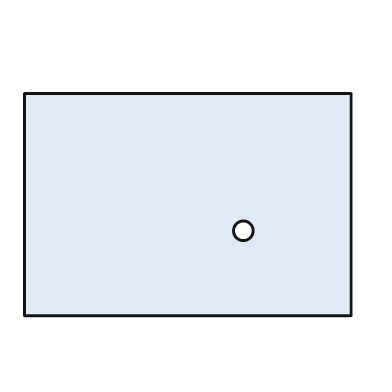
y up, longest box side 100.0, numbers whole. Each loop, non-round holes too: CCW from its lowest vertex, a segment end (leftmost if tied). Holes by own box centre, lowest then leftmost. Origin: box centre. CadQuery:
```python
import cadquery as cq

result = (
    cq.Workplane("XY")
    .moveTo(-50.0, -34.0)
    .lineTo(50.0, -34.0)
    .lineTo(50.0, 34.0)
    .lineTo(-50.0, 34.0)
    .close()
    .moveTo(17.0, -8.0)
    .circle(3.0)
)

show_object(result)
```